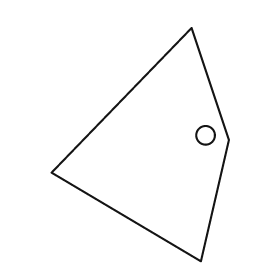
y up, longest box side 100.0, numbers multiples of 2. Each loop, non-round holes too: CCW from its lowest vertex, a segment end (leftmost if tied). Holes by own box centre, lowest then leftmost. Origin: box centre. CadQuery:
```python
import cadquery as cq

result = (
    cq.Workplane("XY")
    .moveTo(26.0, -50.0)
    .lineTo(38.0, 2.0)
    .lineTo(22.0, 50.0)
    .lineTo(-38.0, -12.0)
    .close()
    .moveTo(28.0, 4.0)
    .circle(4.0)
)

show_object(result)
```